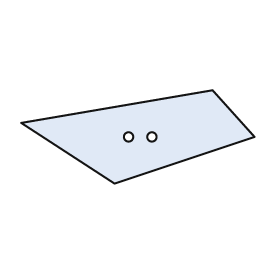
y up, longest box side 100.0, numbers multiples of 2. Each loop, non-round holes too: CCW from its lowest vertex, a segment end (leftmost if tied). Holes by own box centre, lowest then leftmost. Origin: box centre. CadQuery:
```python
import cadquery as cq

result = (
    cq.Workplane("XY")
    .moveTo(-10.0, -20.0)
    .lineTo(50.0, 0.0)
    .lineTo(32.0, 20.0)
    .lineTo(-50.0, 6.0)
    .close()
    .moveTo(-4.0, 0.0)
    .circle(2.0)
    .moveTo(6.0, 0.0)
    .circle(2.0)
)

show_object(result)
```